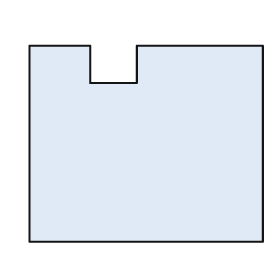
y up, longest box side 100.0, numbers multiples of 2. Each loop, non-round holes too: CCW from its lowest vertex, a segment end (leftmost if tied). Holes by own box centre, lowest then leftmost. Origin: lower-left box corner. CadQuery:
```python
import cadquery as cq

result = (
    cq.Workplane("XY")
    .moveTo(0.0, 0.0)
    .lineTo(100.0, 0.0)
    .lineTo(100.0, 84.0)
    .lineTo(46.0, 84.0)
    .lineTo(46.0, 68.0)
    .lineTo(26.0, 68.0)
    .lineTo(26.0, 84.0)
    .lineTo(0.0, 84.0)
    .close()
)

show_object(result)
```